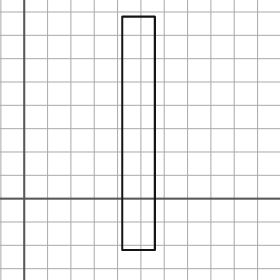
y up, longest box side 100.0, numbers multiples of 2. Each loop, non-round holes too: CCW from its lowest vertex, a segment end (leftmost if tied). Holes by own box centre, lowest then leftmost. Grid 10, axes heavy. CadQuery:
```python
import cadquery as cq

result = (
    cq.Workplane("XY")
    .moveTo(42.0, -22.0)
    .lineTo(56.0, -22.0)
    .lineTo(56.0, 78.0)
    .lineTo(42.0, 78.0)
    .close()
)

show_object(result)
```